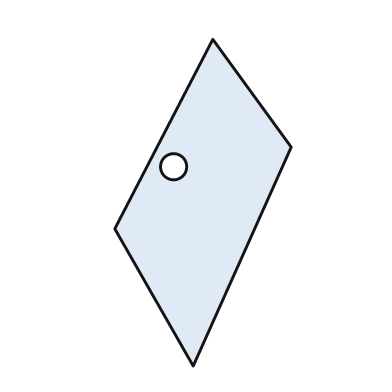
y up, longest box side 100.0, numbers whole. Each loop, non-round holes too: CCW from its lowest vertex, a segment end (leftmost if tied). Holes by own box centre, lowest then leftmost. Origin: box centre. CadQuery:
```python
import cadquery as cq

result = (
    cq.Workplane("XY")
    .moveTo(-3.0, -50.0)
    .lineTo(27.0, 17.0)
    .lineTo(3.0, 50.0)
    .lineTo(-27.0, -8.0)
    .close()
    .moveTo(-9.0, 11.0)
    .circle(4.0)
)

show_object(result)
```